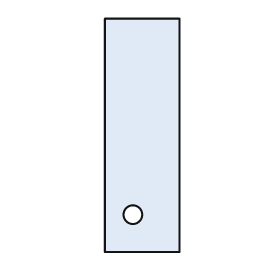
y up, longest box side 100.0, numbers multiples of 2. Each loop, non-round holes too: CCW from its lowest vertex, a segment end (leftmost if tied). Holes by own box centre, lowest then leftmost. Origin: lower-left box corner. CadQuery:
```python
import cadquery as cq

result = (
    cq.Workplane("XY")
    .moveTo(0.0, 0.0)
    .lineTo(32.0, 0.0)
    .lineTo(32.0, 100.0)
    .lineTo(0.0, 100.0)
    .close()
    .moveTo(12.0, 16.0)
    .circle(4.0)
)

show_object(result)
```